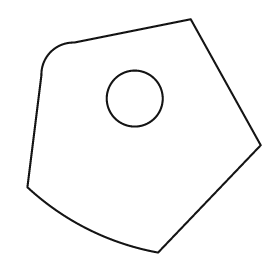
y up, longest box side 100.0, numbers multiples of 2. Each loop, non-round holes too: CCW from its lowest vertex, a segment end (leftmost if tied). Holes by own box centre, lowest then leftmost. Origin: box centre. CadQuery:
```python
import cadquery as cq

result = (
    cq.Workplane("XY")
    .moveTo(6.0, -50.0)
    .lineTo(50.0, -4.0)
    .lineTo(20.0, 50.0)
    .lineTo(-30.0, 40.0)
    .threePointArc((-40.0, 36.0), (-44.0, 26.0))
    .lineTo(-50.0, -22.0)
    .threePointArc((-24.0, -40.0), (6.0, -50.0))
    .close()
    .moveTo(-4.0, 16.0)
    .circle(12.0)
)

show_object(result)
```